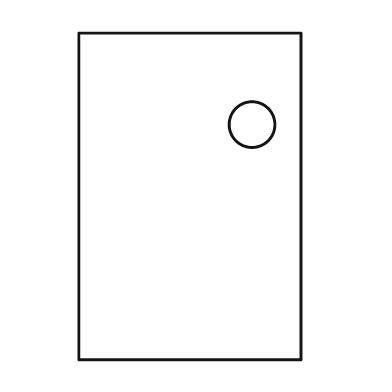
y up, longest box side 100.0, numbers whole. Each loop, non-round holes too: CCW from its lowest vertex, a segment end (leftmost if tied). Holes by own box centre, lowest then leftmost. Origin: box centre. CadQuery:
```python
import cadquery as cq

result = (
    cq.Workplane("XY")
    .moveTo(-34.0, -50.0)
    .lineTo(34.0, -50.0)
    .lineTo(34.0, 50.0)
    .lineTo(-34.0, 50.0)
    .close()
    .moveTo(19.0, 22.0)
    .circle(7.0)
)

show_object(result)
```